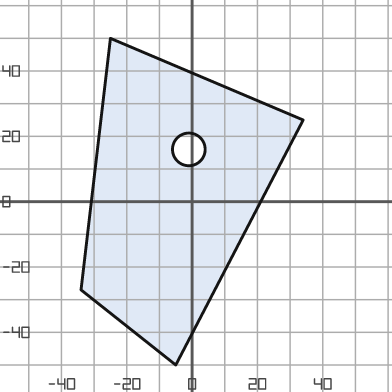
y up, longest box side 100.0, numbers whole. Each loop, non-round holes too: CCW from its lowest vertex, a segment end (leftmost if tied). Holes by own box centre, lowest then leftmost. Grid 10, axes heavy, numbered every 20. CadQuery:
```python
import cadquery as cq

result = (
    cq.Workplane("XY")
    .moveTo(-5.0, -50.0)
    .lineTo(34.0, 25.0)
    .lineTo(-25.0, 50.0)
    .lineTo(-34.0, -27.0)
    .close()
    .moveTo(-1.0, 16.0)
    .circle(5.0)
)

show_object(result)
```